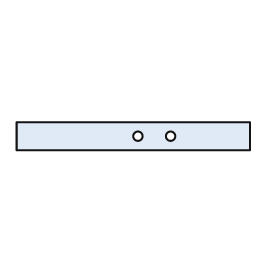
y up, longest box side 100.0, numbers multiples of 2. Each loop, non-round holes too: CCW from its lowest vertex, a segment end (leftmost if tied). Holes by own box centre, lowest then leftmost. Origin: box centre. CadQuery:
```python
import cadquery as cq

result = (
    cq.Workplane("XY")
    .moveTo(-50.0, -6.0)
    .lineTo(50.0, -6.0)
    .lineTo(50.0, 6.0)
    .lineTo(-50.0, 6.0)
    .close()
    .moveTo(2.0, 0.0)
    .circle(2.0)
    .moveTo(16.0, 0.0)
    .circle(2.0)
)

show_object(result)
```